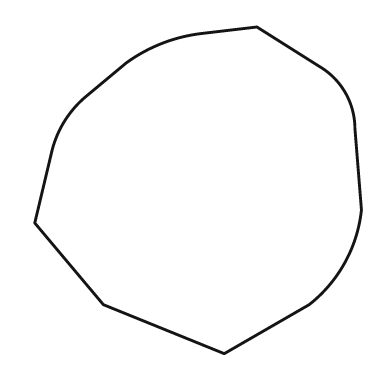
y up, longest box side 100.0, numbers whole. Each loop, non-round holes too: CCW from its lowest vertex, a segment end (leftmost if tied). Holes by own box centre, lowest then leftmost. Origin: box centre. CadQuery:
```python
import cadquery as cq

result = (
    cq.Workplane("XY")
    .moveTo(8.0, -50.0)
    .lineTo(34.0, -35.0)
    .threePointArc((45.0, -22.0), (50.0, -6.0))
    .lineTo(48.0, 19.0)
    .threePointArc((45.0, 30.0), (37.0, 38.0))
    .lineTo(18.0, 50.0)
    .lineTo(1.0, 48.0)
    .threePointArc((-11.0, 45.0), (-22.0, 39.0))
    .lineTo(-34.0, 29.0)
    .threePointArc((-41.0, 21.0), (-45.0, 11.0))
    .lineTo(-50.0, -10.0)
    .lineTo(-29.0, -35.0)
    .close()
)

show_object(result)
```